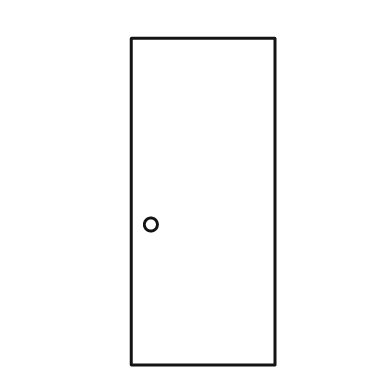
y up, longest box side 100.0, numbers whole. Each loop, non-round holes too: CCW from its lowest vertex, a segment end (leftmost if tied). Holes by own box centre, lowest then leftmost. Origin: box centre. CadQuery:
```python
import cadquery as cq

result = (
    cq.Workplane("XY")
    .moveTo(-22.0, -50.0)
    .lineTo(22.0, -50.0)
    .lineTo(22.0, 50.0)
    .lineTo(-22.0, 50.0)
    .close()
    .moveTo(-16.0, -7.0)
    .circle(2.0)
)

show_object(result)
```